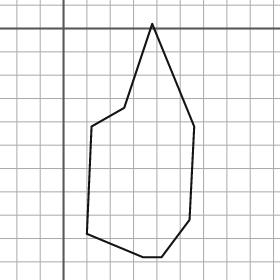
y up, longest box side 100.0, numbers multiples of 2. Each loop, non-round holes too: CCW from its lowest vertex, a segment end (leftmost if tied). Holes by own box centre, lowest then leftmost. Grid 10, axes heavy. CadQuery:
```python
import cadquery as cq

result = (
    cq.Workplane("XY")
    .moveTo(34.0, -98.0)
    .lineTo(42.0, -98.0)
    .lineTo(54.0, -82.0)
    .lineTo(56.0, -42.0)
    .lineTo(38.0, 2.0)
    .lineTo(26.0, -34.0)
    .lineTo(12.0, -42.0)
    .lineTo(10.0, -88.0)
    .close()
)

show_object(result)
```